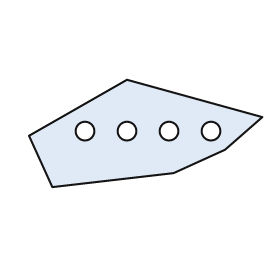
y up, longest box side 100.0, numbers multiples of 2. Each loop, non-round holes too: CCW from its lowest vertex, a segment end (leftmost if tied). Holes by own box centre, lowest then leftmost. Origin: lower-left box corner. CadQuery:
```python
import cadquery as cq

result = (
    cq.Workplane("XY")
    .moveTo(10.0, 0.0)
    .lineTo(62.0, 6.0)
    .lineTo(84.0, 16.0)
    .lineTo(100.0, 30.0)
    .lineTo(42.0, 46.0)
    .lineTo(0.0, 22.0)
    .close()
    .moveTo(24.0, 24.0)
    .circle(4.0)
    .moveTo(42.0, 24.0)
    .circle(4.0)
    .moveTo(60.0, 24.0)
    .circle(4.0)
    .moveTo(78.0, 24.0)
    .circle(4.0)
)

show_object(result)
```